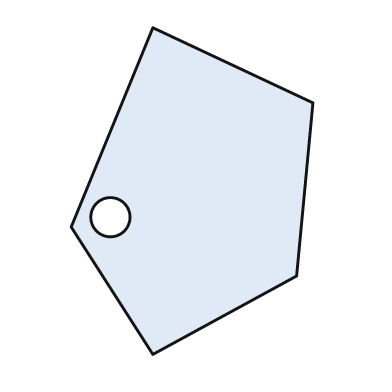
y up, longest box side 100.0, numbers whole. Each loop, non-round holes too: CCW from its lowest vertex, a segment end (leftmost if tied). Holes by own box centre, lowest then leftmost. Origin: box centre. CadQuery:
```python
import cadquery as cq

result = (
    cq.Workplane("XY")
    .moveTo(-12.0, -50.0)
    .lineTo(32.0, -26.0)
    .lineTo(37.0, 27.0)
    .lineTo(-12.0, 50.0)
    .lineTo(-37.0, -11.0)
    .close()
    .moveTo(-25.0, -8.0)
    .circle(6.0)
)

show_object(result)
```